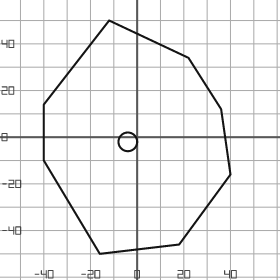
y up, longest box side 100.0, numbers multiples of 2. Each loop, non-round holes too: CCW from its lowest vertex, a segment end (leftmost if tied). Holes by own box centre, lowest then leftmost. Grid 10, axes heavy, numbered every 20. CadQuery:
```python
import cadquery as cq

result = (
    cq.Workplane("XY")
    .moveTo(-16.0, -50.0)
    .lineTo(18.0, -46.0)
    .lineTo(40.0, -16.0)
    .lineTo(36.0, 12.0)
    .lineTo(22.0, 34.0)
    .lineTo(-12.0, 50.0)
    .lineTo(-40.0, 14.0)
    .lineTo(-40.0, -10.0)
    .close()
    .moveTo(-4.0, -2.0)
    .circle(4.0)
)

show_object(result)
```